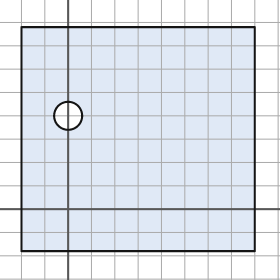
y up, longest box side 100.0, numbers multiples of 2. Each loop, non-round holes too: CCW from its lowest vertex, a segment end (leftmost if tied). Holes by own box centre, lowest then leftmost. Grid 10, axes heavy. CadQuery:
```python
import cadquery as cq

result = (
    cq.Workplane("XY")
    .moveTo(-20.0, -18.0)
    .lineTo(80.0, -18.0)
    .lineTo(80.0, 78.0)
    .lineTo(-20.0, 78.0)
    .close()
    .moveTo(0.0, 40.0)
    .circle(6.0)
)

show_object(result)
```